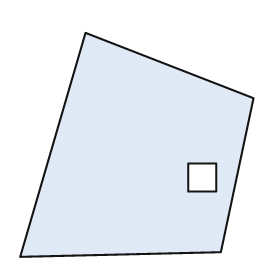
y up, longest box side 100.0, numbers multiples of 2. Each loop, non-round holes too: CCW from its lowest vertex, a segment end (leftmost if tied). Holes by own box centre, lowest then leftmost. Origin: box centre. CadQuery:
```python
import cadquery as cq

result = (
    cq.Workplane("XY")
    .moveTo(-50.0, -48.0)
    .lineTo(36.0, -46.0)
    .lineTo(50.0, 20.0)
    .lineTo(-22.0, 48.0)
    .close()
    .moveTo(22.0, -20.0)
    .lineTo(34.0, -20.0)
    .lineTo(34.0, -8.0)
    .lineTo(22.0, -8.0)
    .close()
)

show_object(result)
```